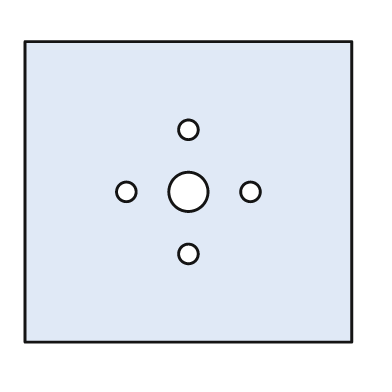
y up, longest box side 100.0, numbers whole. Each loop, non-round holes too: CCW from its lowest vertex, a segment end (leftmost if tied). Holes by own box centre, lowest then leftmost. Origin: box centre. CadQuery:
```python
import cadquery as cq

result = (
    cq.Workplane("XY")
    .moveTo(-50.0, -46.0)
    .lineTo(50.0, -46.0)
    .lineTo(50.0, 46.0)
    .lineTo(-50.0, 46.0)
    .close()
    .moveTo(0.0, -19.0)
    .circle(3.0)
    .moveTo(-19.0, 0.0)
    .circle(3.0)
    .moveTo(0.0, 0.0)
    .circle(6.0)
    .moveTo(19.0, 0.0)
    .circle(3.0)
    .moveTo(0.0, 19.0)
    .circle(3.0)
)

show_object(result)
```